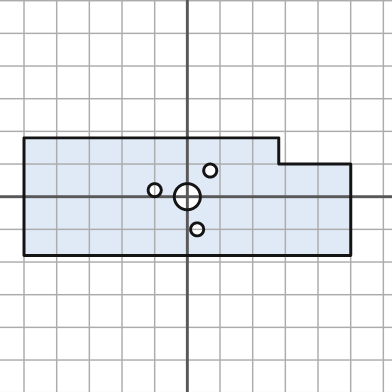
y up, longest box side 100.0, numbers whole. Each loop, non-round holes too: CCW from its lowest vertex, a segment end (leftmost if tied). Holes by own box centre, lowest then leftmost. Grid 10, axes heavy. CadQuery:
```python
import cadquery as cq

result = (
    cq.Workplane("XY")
    .moveTo(-50.0, -18.0)
    .lineTo(50.0, -18.0)
    .lineTo(50.0, 10.0)
    .lineTo(28.0, 10.0)
    .lineTo(28.0, 18.0)
    .lineTo(-50.0, 18.0)
    .close()
    .moveTo(3.0, -10.0)
    .circle(2.0)
    .moveTo(0.0, 0.0)
    .circle(4.0)
    .moveTo(-10.0, 2.0)
    .circle(2.0)
    .moveTo(7.0, 8.0)
    .circle(2.0)
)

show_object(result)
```